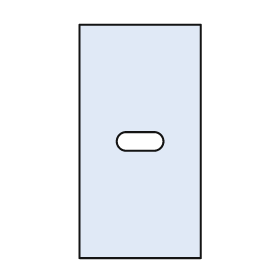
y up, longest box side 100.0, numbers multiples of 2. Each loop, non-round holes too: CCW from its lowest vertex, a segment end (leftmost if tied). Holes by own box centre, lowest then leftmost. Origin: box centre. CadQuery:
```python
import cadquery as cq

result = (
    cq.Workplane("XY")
    .moveTo(-26.0, -50.0)
    .lineTo(26.0, -50.0)
    .lineTo(26.0, 50.0)
    .lineTo(-26.0, 50.0)
    .close()
    .moveTo(-6.0, -4.0)
    .lineTo(6.0, -4.0)
    .threePointArc((10.0, 0.0), (6.0, 4.0))
    .lineTo(-6.0, 4.0)
    .threePointArc((-10.0, 0.0), (-6.0, -4.0))
    .close()
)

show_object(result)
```